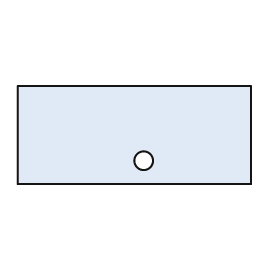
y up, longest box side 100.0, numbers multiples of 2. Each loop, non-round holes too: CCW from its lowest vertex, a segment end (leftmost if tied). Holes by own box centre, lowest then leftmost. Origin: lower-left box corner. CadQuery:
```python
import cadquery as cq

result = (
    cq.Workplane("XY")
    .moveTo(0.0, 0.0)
    .lineTo(100.0, 0.0)
    .lineTo(100.0, 42.0)
    .lineTo(0.0, 42.0)
    .close()
    .moveTo(54.0, 10.0)
    .circle(4.0)
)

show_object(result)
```